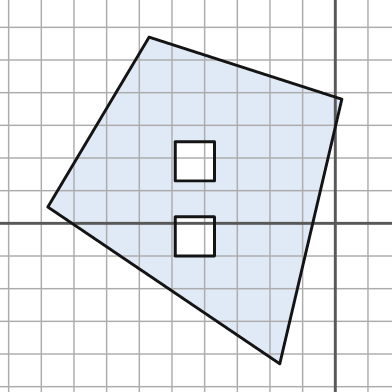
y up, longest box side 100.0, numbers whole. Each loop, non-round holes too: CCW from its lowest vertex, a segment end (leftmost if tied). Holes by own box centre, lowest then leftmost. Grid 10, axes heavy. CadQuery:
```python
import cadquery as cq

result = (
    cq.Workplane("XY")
    .moveTo(-17.0, -43.0)
    .lineTo(2.0, 38.0)
    .lineTo(-57.0, 57.0)
    .lineTo(-88.0, 5.0)
    .close()
    .moveTo(-49.0, -10.0)
    .lineTo(-37.0, -10.0)
    .lineTo(-37.0, 2.0)
    .lineTo(-49.0, 2.0)
    .close()
    .moveTo(-49.0, 13.0)
    .lineTo(-37.0, 13.0)
    .lineTo(-37.0, 25.0)
    .lineTo(-49.0, 25.0)
    .close()
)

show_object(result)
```